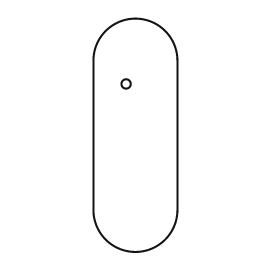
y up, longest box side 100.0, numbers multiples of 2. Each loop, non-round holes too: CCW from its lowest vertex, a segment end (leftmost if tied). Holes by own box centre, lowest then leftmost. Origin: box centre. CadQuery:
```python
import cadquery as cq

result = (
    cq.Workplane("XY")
    .moveTo(-18.0, -32.0)
    .threePointArc((0.0, -50.0), (18.0, -32.0))
    .lineTo(18.0, 32.0)
    .threePointArc((0.0, 50.0), (-18.0, 32.0))
    .close()
    .moveTo(-4.0, 22.0)
    .circle(2.0)
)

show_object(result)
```